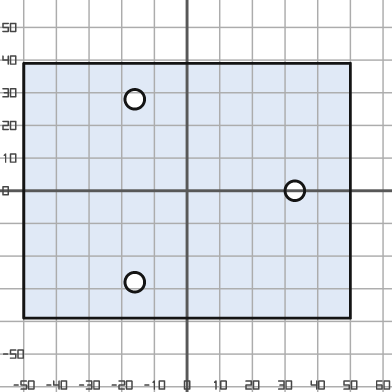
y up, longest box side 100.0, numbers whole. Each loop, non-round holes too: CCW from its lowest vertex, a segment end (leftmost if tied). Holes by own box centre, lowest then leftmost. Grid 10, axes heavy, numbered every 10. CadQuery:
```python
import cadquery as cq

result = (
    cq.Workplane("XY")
    .moveTo(-50.0, -39.0)
    .lineTo(50.0, -39.0)
    .lineTo(50.0, 39.0)
    .lineTo(-50.0, 39.0)
    .close()
    .moveTo(-16.0, -28.0)
    .circle(3.0)
    .moveTo(33.0, 0.0)
    .circle(3.0)
    .moveTo(-16.0, 28.0)
    .circle(3.0)
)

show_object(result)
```